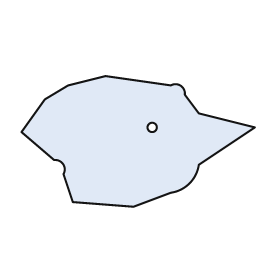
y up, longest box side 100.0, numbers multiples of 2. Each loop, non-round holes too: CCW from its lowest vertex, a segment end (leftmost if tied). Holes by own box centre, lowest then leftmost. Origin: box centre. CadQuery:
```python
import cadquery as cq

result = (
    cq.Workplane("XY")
    .moveTo(-2.0, -28.0)
    .lineTo(14.0, -22.0)
    .threePointArc((22.0, -18.0), (26.0, -10.0))
    .lineTo(50.0, 6.0)
    .lineTo(26.0, 12.0)
    .lineTo(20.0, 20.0)
    .threePointArc((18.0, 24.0), (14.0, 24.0))
    .lineTo(-14.0, 28.0)
    .lineTo(-30.0, 24.0)
    .lineTo(-40.0, 18.0)
    .lineTo(-50.0, 4.0)
    .lineTo(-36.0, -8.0)
    .threePointArc((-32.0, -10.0), (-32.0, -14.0))
    .lineTo(-28.0, -26.0)
    .close()
    .moveTo(6.0, 6.0)
    .circle(2.0)
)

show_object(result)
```